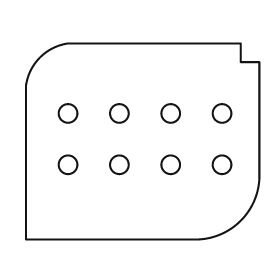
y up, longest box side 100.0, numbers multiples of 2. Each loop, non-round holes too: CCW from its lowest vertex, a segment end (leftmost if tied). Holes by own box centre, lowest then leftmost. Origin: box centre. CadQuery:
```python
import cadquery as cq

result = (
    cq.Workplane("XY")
    .moveTo(-50.0, -42.0)
    .lineTo(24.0, -42.0)
    .threePointArc((42.0, -34.0), (50.0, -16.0))
    .lineTo(50.0, 34.0)
    .lineTo(42.0, 34.0)
    .lineTo(42.0, 42.0)
    .lineTo(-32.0, 42.0)
    .threePointArc((-44.0, 36.0), (-50.0, 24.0))
    .close()
    .moveTo(-32.0, -10.0)
    .circle(4.0)
    .moveTo(-10.0, -10.0)
    .circle(4.0)
    .moveTo(12.0, -10.0)
    .circle(4.0)
    .moveTo(34.0, -10.0)
    .circle(4.0)
    .moveTo(-32.0, 12.0)
    .circle(4.0)
    .moveTo(-10.0, 12.0)
    .circle(4.0)
    .moveTo(12.0, 12.0)
    .circle(4.0)
    .moveTo(34.0, 12.0)
    .circle(4.0)
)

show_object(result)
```